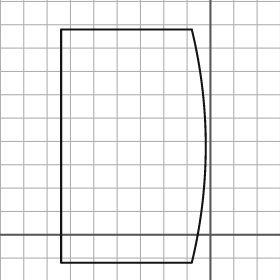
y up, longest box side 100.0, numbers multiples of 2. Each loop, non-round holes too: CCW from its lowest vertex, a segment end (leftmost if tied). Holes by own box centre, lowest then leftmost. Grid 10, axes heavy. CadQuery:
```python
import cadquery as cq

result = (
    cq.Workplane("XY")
    .moveTo(-64.0, -12.0)
    .lineTo(-8.0, -12.0)
    .threePointArc((-2.0, 38.0), (-8.0, 88.0))
    .lineTo(-64.0, 88.0)
    .close()
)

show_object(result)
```